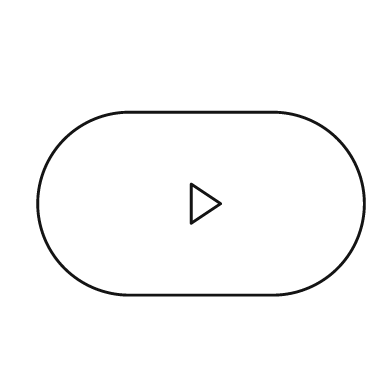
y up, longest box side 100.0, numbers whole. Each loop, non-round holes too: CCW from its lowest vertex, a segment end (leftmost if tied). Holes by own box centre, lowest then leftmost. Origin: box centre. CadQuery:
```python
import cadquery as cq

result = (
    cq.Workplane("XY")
    .moveTo(-22.0, -28.0)
    .lineTo(22.0, -28.0)
    .threePointArc((50.0, 0.0), (22.0, 28.0))
    .lineTo(-22.0, 28.0)
    .threePointArc((-50.0, 0.0), (-22.0, -28.0))
    .close()
    .moveTo(-3.0, -6.0)
    .lineTo(6.0, 0.0)
    .lineTo(-3.0, 6.0)
    .close()
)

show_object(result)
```